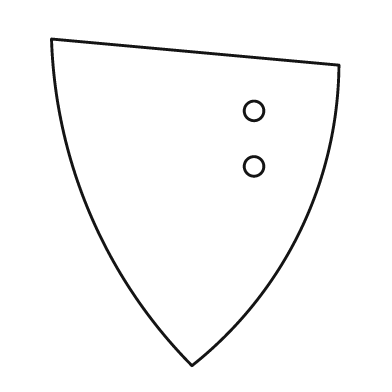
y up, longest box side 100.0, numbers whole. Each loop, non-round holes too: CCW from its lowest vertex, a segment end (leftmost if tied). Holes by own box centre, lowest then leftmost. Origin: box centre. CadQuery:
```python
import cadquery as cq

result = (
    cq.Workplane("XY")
    .moveTo(-1.0, -50.0)
    .threePointArc((32.0, -9.0), (44.0, 42.0))
    .lineTo(-44.0, 50.0)
    .threePointArc((-32.0, -4.0), (-1.0, -50.0))
    .close()
    .moveTo(18.0, 11.0)
    .circle(3.0)
    .moveTo(18.0, 28.0)
    .circle(3.0)
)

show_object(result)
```